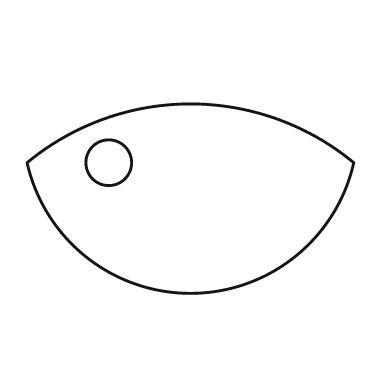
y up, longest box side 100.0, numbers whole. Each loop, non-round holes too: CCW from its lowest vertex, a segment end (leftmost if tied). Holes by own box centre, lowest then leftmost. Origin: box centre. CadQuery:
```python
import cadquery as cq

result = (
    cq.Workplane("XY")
    .moveTo(-50.0, 11.0)
    .threePointArc((0.0, -29.0), (50.0, 11.0))
    .threePointArc((0.0, 29.0), (-50.0, 11.0))
    .close()
    .moveTo(-25.0, 11.0)
    .circle(7.0)
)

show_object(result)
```